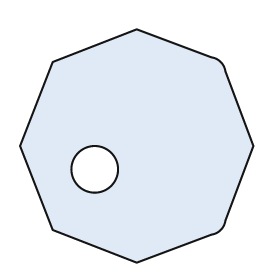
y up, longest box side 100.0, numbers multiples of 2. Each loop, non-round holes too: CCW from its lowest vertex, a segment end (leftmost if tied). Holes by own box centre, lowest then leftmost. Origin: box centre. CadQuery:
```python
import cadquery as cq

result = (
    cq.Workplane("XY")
    .moveTo(0.0, -50.0)
    .lineTo(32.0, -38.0)
    .threePointArc((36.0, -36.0), (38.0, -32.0))
    .lineTo(50.0, 0.0)
    .lineTo(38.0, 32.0)
    .threePointArc((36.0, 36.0), (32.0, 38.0))
    .lineTo(0.0, 50.0)
    .lineTo(-36.0, 36.0)
    .lineTo(-50.0, 0.0)
    .lineTo(-36.0, -36.0)
    .close()
    .moveTo(-18.0, -10.0)
    .circle(10.0)
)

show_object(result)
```